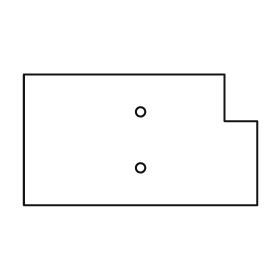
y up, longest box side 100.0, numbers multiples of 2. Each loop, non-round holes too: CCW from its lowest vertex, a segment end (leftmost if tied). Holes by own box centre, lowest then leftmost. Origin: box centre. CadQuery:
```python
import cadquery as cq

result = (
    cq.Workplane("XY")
    .moveTo(-50.0, -28.0)
    .lineTo(50.0, -28.0)
    .lineTo(50.0, 8.0)
    .lineTo(36.0, 8.0)
    .lineTo(36.0, 28.0)
    .lineTo(-50.0, 28.0)
    .close()
    .moveTo(0.0, -12.0)
    .circle(2.0)
    .moveTo(0.0, 12.0)
    .circle(2.0)
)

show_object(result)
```